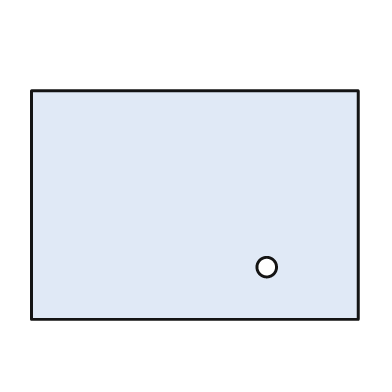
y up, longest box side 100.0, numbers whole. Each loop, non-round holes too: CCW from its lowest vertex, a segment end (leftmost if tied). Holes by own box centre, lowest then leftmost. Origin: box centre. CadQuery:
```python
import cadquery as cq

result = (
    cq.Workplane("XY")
    .moveTo(-50.0, -35.0)
    .lineTo(50.0, -35.0)
    .lineTo(50.0, 35.0)
    .lineTo(-50.0, 35.0)
    .close()
    .moveTo(22.0, -19.0)
    .circle(3.0)
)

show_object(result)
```